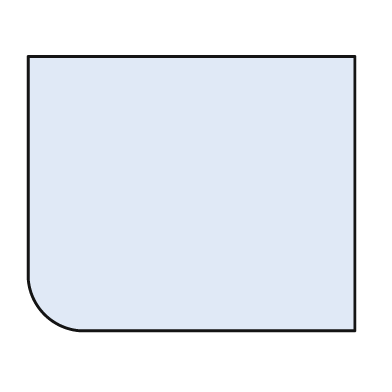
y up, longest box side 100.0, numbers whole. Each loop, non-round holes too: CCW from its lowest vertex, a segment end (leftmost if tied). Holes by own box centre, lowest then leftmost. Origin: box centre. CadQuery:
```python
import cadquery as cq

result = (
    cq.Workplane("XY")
    .moveTo(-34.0, -42.0)
    .lineTo(50.0, -42.0)
    .lineTo(50.0, 42.0)
    .lineTo(-50.0, 42.0)
    .lineTo(-50.0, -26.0)
    .threePointArc((-45.0, -37.0), (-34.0, -42.0))
    .close()
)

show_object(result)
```